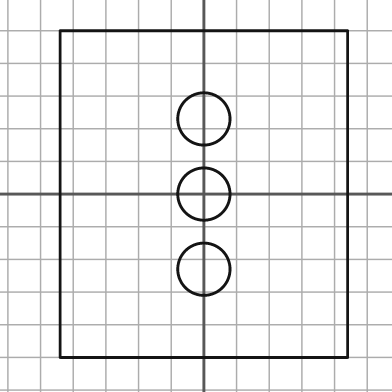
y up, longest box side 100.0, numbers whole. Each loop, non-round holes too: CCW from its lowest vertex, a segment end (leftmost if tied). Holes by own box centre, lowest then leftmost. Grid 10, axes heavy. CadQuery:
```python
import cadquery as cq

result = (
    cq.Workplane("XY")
    .moveTo(-44.0, -50.0)
    .lineTo(44.0, -50.0)
    .lineTo(44.0, 50.0)
    .lineTo(-44.0, 50.0)
    .close()
    .moveTo(0.0, -23.0)
    .circle(8.0)
    .moveTo(0.0, 0.0)
    .circle(8.0)
    .moveTo(0.0, 23.0)
    .circle(8.0)
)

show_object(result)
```